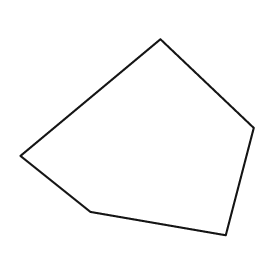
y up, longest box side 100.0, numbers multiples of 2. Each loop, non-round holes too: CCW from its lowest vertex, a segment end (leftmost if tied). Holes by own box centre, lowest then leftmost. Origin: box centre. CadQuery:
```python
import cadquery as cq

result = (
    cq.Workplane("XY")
    .moveTo(38.0, -42.0)
    .lineTo(50.0, 4.0)
    .lineTo(10.0, 42.0)
    .lineTo(-50.0, -8.0)
    .lineTo(-20.0, -32.0)
    .close()
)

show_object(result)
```